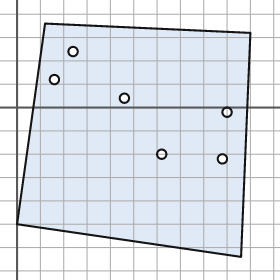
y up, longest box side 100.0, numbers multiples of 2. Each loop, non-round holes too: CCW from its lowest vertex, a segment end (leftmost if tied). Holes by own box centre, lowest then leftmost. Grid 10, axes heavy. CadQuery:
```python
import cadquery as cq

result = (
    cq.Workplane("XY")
    .moveTo(96.0, -64.0)
    .lineTo(100.0, 32.0)
    .lineTo(12.0, 36.0)
    .lineTo(0.0, -50.0)
    .close()
    .moveTo(88.0, -22.0)
    .circle(2.0)
    .moveTo(62.0, -20.0)
    .circle(2.0)
    .moveTo(90.0, -2.0)
    .circle(2.0)
    .moveTo(46.0, 4.0)
    .circle(2.0)
    .moveTo(16.0, 12.0)
    .circle(2.0)
    .moveTo(24.0, 24.0)
    .circle(2.0)
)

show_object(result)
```